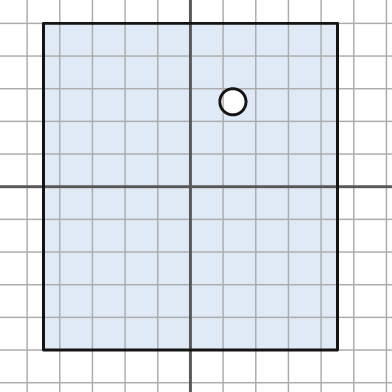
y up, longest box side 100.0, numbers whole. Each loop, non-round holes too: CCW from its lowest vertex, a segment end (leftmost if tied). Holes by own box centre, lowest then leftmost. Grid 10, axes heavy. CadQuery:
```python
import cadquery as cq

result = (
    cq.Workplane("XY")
    .moveTo(-45.0, -50.0)
    .lineTo(45.0, -50.0)
    .lineTo(45.0, 50.0)
    .lineTo(-45.0, 50.0)
    .close()
    .moveTo(13.0, 26.0)
    .circle(4.0)
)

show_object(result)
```